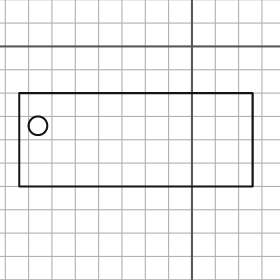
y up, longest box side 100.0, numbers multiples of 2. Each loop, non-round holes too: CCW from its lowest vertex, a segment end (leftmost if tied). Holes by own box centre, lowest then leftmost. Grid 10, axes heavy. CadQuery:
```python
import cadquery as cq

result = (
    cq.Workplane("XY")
    .moveTo(-74.0, -60.0)
    .lineTo(26.0, -60.0)
    .lineTo(26.0, -20.0)
    .lineTo(-74.0, -20.0)
    .close()
    .moveTo(-66.0, -34.0)
    .circle(4.0)
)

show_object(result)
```